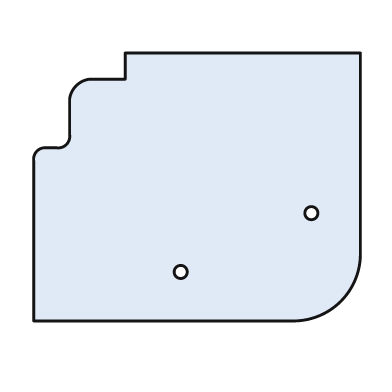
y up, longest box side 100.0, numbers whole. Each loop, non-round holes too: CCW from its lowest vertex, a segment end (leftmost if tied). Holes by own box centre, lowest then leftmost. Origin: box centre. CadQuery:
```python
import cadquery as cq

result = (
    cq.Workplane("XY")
    .moveTo(-50.0, -41.0)
    .lineTo(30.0, -41.0)
    .threePointArc((44.0, -35.0), (50.0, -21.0))
    .lineTo(50.0, 41.0)
    .lineTo(-22.0, 41.0)
    .lineTo(-22.0, 33.0)
    .lineTo(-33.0, 33.0)
    .threePointArc((-37.0, 31.0), (-39.0, 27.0))
    .lineTo(-39.0, 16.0)
    .threePointArc((-40.0, 13.0), (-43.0, 12.0))
    .lineTo(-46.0, 12.0)
    .threePointArc((-49.0, 11.0), (-50.0, 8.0))
    .close()
    .moveTo(-5.0, -26.0)
    .circle(2.0)
    .moveTo(35.0, -8.0)
    .circle(2.0)
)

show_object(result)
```